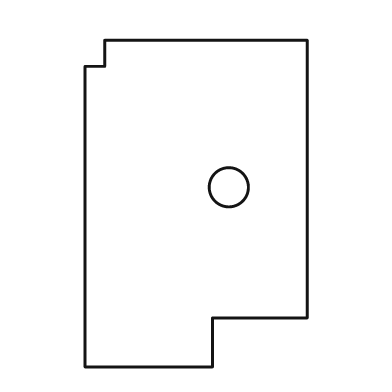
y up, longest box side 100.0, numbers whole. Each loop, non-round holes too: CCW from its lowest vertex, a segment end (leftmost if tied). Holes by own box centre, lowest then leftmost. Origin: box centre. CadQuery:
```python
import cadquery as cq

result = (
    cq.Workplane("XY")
    .moveTo(-34.0, -50.0)
    .lineTo(5.0, -50.0)
    .lineTo(5.0, -35.0)
    .lineTo(34.0, -35.0)
    .lineTo(34.0, 50.0)
    .lineTo(-28.0, 50.0)
    .lineTo(-28.0, 42.0)
    .lineTo(-34.0, 42.0)
    .close()
    .moveTo(10.0, 5.0)
    .circle(6.0)
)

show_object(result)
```